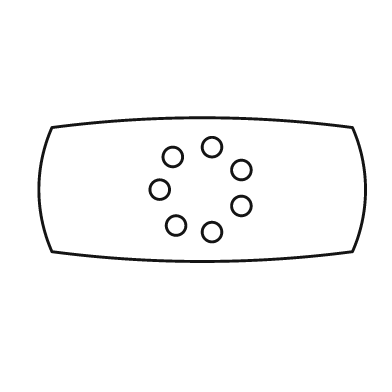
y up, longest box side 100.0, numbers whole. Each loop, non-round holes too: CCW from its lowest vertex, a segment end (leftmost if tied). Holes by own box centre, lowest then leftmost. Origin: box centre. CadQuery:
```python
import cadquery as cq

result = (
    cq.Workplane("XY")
    .moveTo(-46.0, -19.0)
    .threePointArc((0.0, -22.0), (46.0, -19.0))
    .threePointArc((50.0, 0.0), (46.0, 19.0))
    .threePointArc((0.0, 22.0), (-46.0, 19.0))
    .threePointArc((-50.0, 0.0), (-46.0, -19.0))
    .close()
    .moveTo(3.0, -13.0)
    .circle(3.0)
    .moveTo(-8.0, -11.0)
    .circle(3.0)
    .moveTo(12.0, -5.0)
    .circle(3.0)
    .moveTo(-13.0, 0.0)
    .circle(3.0)
    .moveTo(12.0, 6.0)
    .circle(3.0)
    .moveTo(-9.0, 10.0)
    .circle(3.0)
    .moveTo(3.0, 13.0)
    .circle(3.0)
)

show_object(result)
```